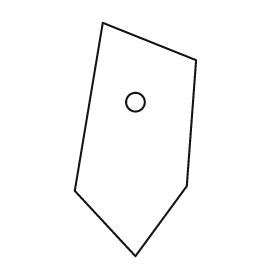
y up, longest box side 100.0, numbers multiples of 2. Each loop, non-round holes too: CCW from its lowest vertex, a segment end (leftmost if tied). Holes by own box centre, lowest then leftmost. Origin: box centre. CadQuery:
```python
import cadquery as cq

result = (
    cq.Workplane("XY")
    .moveTo(0.0, -50.0)
    .lineTo(22.0, -20.0)
    .lineTo(26.0, 34.0)
    .lineTo(-14.0, 50.0)
    .lineTo(-26.0, -22.0)
    .close()
    .moveTo(0.0, 16.0)
    .circle(4.0)
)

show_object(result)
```